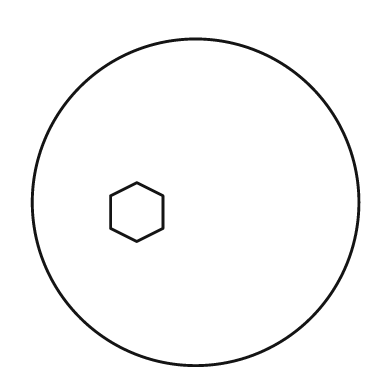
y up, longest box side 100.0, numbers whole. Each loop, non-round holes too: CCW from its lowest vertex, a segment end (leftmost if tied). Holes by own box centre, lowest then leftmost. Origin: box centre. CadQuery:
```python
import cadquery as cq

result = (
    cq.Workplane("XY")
    .moveTo(0.0, 0.0)
    .circle(50.0)
    .moveTo(-18.0, -12.0)
    .lineTo(-10.0, -8.0)
    .lineTo(-10.0, 2.0)
    .lineTo(-18.0, 6.0)
    .lineTo(-26.0, 2.0)
    .lineTo(-26.0, -8.0)
    .close()
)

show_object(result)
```